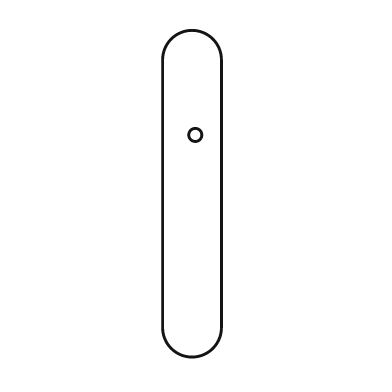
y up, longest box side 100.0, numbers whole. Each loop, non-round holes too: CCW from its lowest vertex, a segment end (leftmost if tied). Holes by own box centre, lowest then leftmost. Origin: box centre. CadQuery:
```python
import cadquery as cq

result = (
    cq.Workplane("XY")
    .moveTo(-9.0, -41.0)
    .threePointArc((0.0, -50.0), (9.0, -41.0))
    .lineTo(9.0, 41.0)
    .threePointArc((0.0, 50.0), (-9.0, 41.0))
    .close()
    .moveTo(1.0, 18.0)
    .circle(2.0)
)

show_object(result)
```